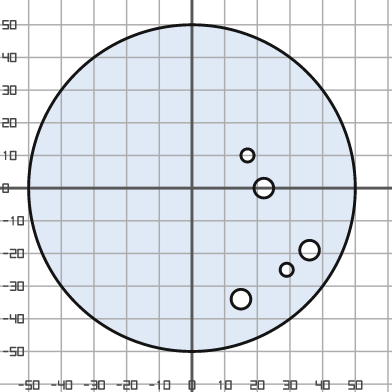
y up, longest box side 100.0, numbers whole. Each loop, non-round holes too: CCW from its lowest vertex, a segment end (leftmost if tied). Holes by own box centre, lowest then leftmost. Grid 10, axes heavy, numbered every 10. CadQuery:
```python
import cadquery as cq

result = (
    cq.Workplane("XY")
    .moveTo(0.0, 0.0)
    .circle(50.0)
    .moveTo(15.0, -34.0)
    .circle(3.0)
    .moveTo(29.0, -25.0)
    .circle(2.0)
    .moveTo(36.0, -19.0)
    .circle(3.0)
    .moveTo(22.0, 0.0)
    .circle(3.0)
    .moveTo(17.0, 10.0)
    .circle(2.0)
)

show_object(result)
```